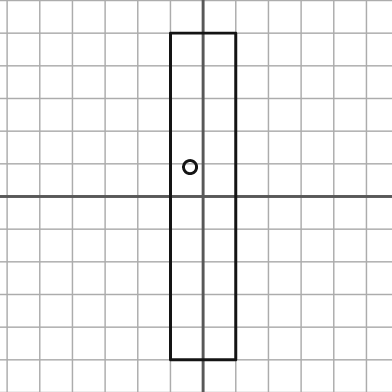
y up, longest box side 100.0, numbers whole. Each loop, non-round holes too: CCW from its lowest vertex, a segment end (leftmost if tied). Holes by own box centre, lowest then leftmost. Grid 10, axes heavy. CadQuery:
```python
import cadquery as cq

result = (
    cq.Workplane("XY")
    .moveTo(-10.0, -50.0)
    .lineTo(10.0, -50.0)
    .lineTo(10.0, 50.0)
    .lineTo(-10.0, 50.0)
    .close()
    .moveTo(-4.0, 9.0)
    .circle(2.0)
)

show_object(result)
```